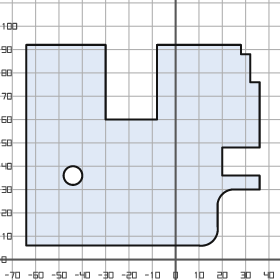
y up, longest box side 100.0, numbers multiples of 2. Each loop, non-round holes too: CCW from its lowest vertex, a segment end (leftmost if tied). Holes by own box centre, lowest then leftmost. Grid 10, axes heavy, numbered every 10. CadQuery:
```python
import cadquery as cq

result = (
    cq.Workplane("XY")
    .moveTo(-64.0, 6.0)
    .lineTo(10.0, 6.0)
    .threePointArc((16.0, 8.0), (18.0, 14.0))
    .lineTo(18.0, 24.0)
    .threePointArc((20.0, 28.0), (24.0, 30.0))
    .lineTo(36.0, 30.0)
    .lineTo(36.0, 36.0)
    .lineTo(20.0, 36.0)
    .lineTo(20.0, 48.0)
    .lineTo(36.0, 48.0)
    .lineTo(36.0, 76.0)
    .lineTo(32.0, 76.0)
    .lineTo(32.0, 88.0)
    .lineTo(28.0, 88.0)
    .lineTo(28.0, 92.0)
    .lineTo(-8.0, 92.0)
    .lineTo(-8.0, 60.0)
    .lineTo(-30.0, 60.0)
    .lineTo(-30.0, 92.0)
    .lineTo(-64.0, 92.0)
    .close()
    .moveTo(-44.0, 36.0)
    .circle(4.0)
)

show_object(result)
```